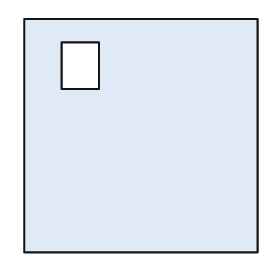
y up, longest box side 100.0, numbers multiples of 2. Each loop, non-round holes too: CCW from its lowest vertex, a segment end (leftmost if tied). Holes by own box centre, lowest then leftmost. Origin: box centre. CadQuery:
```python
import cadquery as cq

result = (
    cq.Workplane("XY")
    .moveTo(-50.0, -50.0)
    .lineTo(50.0, -50.0)
    .lineTo(50.0, 50.0)
    .lineTo(-50.0, 50.0)
    .close()
    .moveTo(-34.0, 20.0)
    .lineTo(-18.0, 20.0)
    .lineTo(-18.0, 40.0)
    .lineTo(-34.0, 40.0)
    .close()
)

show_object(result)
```